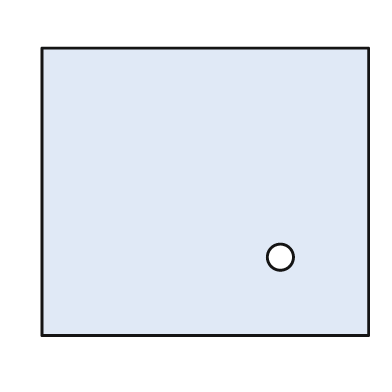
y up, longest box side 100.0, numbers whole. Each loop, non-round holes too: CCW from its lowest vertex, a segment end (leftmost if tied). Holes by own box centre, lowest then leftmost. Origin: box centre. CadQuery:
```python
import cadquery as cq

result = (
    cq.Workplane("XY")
    .moveTo(-50.0, -44.0)
    .lineTo(50.0, -44.0)
    .lineTo(50.0, 44.0)
    .lineTo(-50.0, 44.0)
    .close()
    .moveTo(23.0, -20.0)
    .circle(4.0)
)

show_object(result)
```